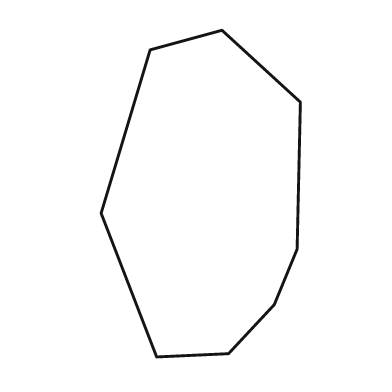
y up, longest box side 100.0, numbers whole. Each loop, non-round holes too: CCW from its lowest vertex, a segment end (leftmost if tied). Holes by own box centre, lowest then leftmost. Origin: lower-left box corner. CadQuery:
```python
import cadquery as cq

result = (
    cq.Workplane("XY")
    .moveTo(17.0, 0.0)
    .lineTo(39.0, 1.0)
    .lineTo(53.0, 16.0)
    .lineTo(60.0, 33.0)
    .lineTo(61.0, 78.0)
    .lineTo(37.0, 100.0)
    .lineTo(15.0, 94.0)
    .lineTo(0.0, 44.0)
    .close()
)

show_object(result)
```